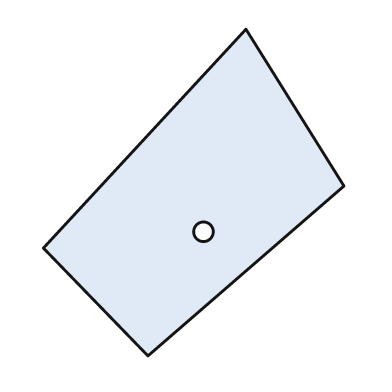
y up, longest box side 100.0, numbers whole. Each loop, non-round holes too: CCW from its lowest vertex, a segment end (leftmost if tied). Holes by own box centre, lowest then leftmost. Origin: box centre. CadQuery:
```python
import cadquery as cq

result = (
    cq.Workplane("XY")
    .moveTo(-14.0, -50.0)
    .lineTo(46.0, 2.0)
    .lineTo(16.0, 50.0)
    .lineTo(-46.0, -17.0)
    .close()
    .moveTo(3.0, -12.0)
    .circle(3.0)
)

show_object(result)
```